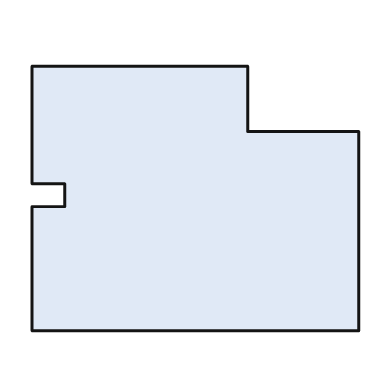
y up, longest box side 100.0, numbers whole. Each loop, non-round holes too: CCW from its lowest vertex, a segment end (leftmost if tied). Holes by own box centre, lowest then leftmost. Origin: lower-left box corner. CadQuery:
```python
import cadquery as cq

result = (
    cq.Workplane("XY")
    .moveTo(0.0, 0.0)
    .lineTo(100.0, 0.0)
    .lineTo(100.0, 61.0)
    .lineTo(66.0, 61.0)
    .lineTo(66.0, 81.0)
    .lineTo(0.0, 81.0)
    .lineTo(0.0, 45.0)
    .lineTo(10.0, 45.0)
    .lineTo(10.0, 38.0)
    .lineTo(0.0, 38.0)
    .close()
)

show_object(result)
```